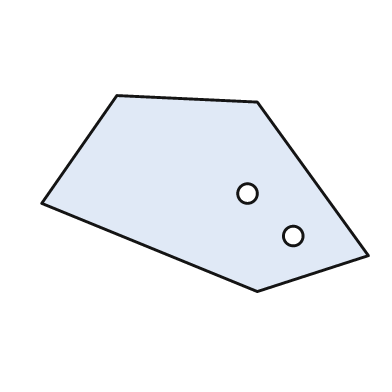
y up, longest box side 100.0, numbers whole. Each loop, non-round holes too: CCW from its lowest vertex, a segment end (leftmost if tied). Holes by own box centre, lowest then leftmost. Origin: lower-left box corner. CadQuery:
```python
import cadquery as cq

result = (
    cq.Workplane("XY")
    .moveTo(66.0, 0.0)
    .lineTo(100.0, 11.0)
    .lineTo(66.0, 58.0)
    .lineTo(23.0, 60.0)
    .lineTo(0.0, 27.0)
    .close()
    .moveTo(77.0, 17.0)
    .circle(3.0)
    .moveTo(63.0, 30.0)
    .circle(3.0)
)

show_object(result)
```